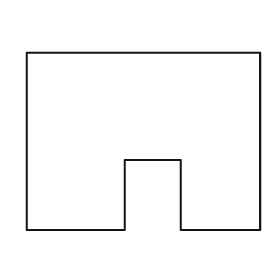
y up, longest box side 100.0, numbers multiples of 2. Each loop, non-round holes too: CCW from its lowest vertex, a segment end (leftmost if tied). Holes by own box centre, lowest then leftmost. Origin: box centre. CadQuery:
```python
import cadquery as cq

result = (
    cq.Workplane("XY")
    .moveTo(-50.0, -38.0)
    .lineTo(-8.0, -38.0)
    .lineTo(-8.0, -8.0)
    .lineTo(16.0, -8.0)
    .lineTo(16.0, -38.0)
    .lineTo(50.0, -38.0)
    .lineTo(50.0, 38.0)
    .lineTo(-50.0, 38.0)
    .close()
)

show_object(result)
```